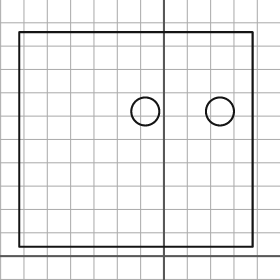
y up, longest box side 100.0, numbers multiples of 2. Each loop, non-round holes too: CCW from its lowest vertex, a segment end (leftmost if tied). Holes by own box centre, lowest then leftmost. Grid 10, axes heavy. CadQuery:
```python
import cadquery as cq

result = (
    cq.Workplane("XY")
    .moveTo(-62.0, 4.0)
    .lineTo(38.0, 4.0)
    .lineTo(38.0, 96.0)
    .lineTo(-62.0, 96.0)
    .close()
    .moveTo(-8.0, 62.0)
    .circle(6.0)
    .moveTo(24.0, 62.0)
    .circle(6.0)
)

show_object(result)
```